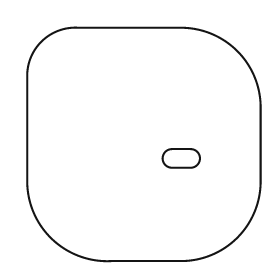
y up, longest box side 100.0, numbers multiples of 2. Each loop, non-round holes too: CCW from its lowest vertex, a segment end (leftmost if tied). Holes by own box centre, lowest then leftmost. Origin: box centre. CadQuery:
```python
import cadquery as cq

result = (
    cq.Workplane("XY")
    .moveTo(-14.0, -50.0)
    .lineTo(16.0, -50.0)
    .threePointArc((40.0, -40.0), (50.0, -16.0))
    .lineTo(50.0, 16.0)
    .threePointArc((40.0, 40.0), (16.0, 50.0))
    .lineTo(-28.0, 50.0)
    .threePointArc((-44.0, 44.0), (-50.0, 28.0))
    .lineTo(-50.0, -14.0)
    .threePointArc((-40.0, -40.0), (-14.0, -50.0))
    .close()
    .moveTo(12.0, -10.0)
    .lineTo(20.0, -10.0)
    .threePointArc((24.0, -6.0), (20.0, -2.0))
    .lineTo(12.0, -2.0)
    .threePointArc((8.0, -6.0), (12.0, -10.0))
    .close()
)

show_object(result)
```